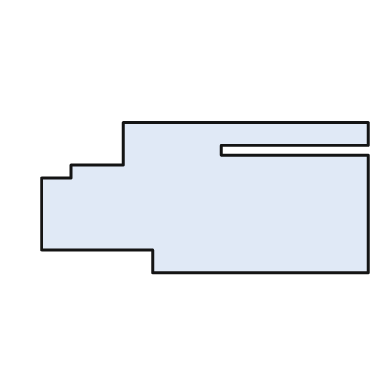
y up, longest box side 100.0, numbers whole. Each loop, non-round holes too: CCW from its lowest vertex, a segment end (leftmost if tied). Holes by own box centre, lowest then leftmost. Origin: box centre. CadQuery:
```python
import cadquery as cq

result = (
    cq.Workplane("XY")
    .moveTo(-16.0, -23.0)
    .lineTo(50.0, -23.0)
    .lineTo(50.0, 13.0)
    .lineTo(5.0, 13.0)
    .lineTo(5.0, 16.0)
    .lineTo(50.0, 16.0)
    .lineTo(50.0, 23.0)
    .lineTo(-25.0, 23.0)
    .lineTo(-25.0, 10.0)
    .lineTo(-41.0, 10.0)
    .lineTo(-41.0, 6.0)
    .lineTo(-50.0, 6.0)
    .lineTo(-50.0, -16.0)
    .lineTo(-16.0, -16.0)
    .close()
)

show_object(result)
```